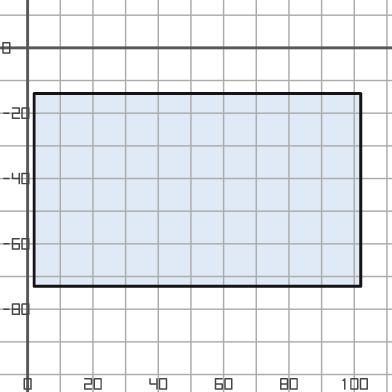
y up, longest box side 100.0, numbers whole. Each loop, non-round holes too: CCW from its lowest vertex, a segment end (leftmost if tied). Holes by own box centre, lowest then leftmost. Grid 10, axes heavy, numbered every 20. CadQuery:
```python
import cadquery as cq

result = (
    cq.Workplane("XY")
    .moveTo(2.0, -73.0)
    .lineTo(102.0, -73.0)
    .lineTo(102.0, -14.0)
    .lineTo(2.0, -14.0)
    .close()
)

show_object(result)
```